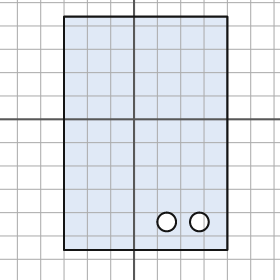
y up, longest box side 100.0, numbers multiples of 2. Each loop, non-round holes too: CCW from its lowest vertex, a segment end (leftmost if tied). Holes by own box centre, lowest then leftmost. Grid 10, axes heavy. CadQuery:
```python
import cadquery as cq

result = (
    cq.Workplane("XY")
    .moveTo(-30.0, -56.0)
    .lineTo(40.0, -56.0)
    .lineTo(40.0, 44.0)
    .lineTo(-30.0, 44.0)
    .close()
    .moveTo(14.0, -44.0)
    .circle(4.0)
    .moveTo(28.0, -44.0)
    .circle(4.0)
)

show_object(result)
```